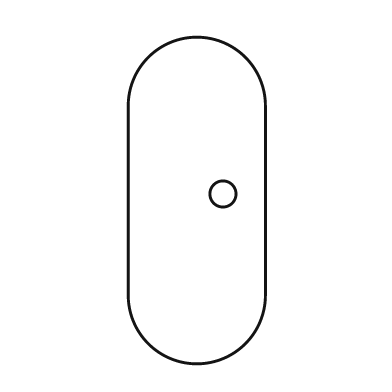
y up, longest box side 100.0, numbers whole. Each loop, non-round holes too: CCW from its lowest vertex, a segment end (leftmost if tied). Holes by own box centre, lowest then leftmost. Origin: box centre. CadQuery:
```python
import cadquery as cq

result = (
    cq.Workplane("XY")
    .moveTo(-21.0, -29.0)
    .threePointArc((0.0, -50.0), (21.0, -29.0))
    .lineTo(21.0, 29.0)
    .threePointArc((0.0, 50.0), (-21.0, 29.0))
    .close()
    .moveTo(8.0, 2.0)
    .circle(4.0)
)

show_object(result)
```